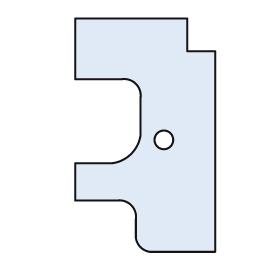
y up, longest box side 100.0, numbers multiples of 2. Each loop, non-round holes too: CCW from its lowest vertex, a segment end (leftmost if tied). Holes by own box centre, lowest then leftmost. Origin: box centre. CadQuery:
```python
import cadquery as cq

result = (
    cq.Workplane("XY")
    .moveTo(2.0, -50.0)
    .lineTo(30.0, -50.0)
    .lineTo(30.0, 36.0)
    .lineTo(18.0, 36.0)
    .lineTo(18.0, 50.0)
    .lineTo(-30.0, 50.0)
    .lineTo(-30.0, 24.0)
    .lineTo(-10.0, 24.0)
    .threePointArc((-4.0, 22.0), (-2.0, 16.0))
    .lineTo(-2.0, 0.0)
    .threePointArc((-6.0, -8.0), (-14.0, -12.0))
    .lineTo(-30.0, -12.0)
    .lineTo(-30.0, -28.0)
    .lineTo(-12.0, -28.0)
    .threePointArc((-6.0, -30.0), (-4.0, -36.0))
    .lineTo(-4.0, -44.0)
    .threePointArc((-2.0, -48.0), (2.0, -50.0))
    .close()
    .moveTo(8.0, -2.0)
    .circle(4.0)
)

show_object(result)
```